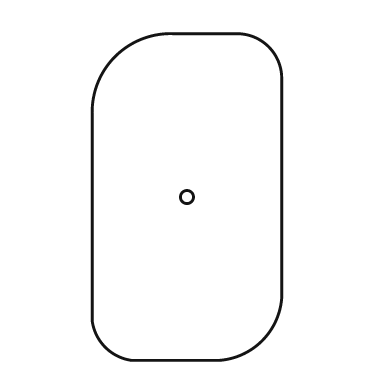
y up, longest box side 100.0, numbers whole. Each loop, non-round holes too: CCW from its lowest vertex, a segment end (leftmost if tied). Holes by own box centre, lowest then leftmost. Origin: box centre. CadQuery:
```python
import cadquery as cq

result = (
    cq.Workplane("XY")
    .moveTo(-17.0, -50.0)
    .lineTo(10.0, -50.0)
    .threePointArc((23.0, -44.0), (29.0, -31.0))
    .lineTo(29.0, 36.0)
    .threePointArc((25.0, 46.0), (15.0, 50.0))
    .lineTo(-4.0, 50.0)
    .threePointArc((-22.0, 43.0), (-29.0, 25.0))
    .lineTo(-29.0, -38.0)
    .threePointArc((-25.0, -46.0), (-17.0, -50.0))
    .close()
    .moveTo(0.0, 0.0)
    .circle(2.0)
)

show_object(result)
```